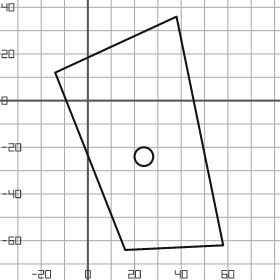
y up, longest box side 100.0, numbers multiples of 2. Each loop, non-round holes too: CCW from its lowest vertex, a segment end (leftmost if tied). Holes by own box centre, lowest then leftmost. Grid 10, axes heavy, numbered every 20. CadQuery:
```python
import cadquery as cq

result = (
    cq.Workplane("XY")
    .moveTo(16.0, -64.0)
    .lineTo(58.0, -62.0)
    .lineTo(38.0, 36.0)
    .lineTo(-14.0, 12.0)
    .close()
    .moveTo(24.0, -24.0)
    .circle(4.0)
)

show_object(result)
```